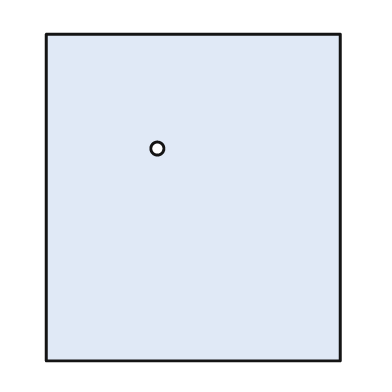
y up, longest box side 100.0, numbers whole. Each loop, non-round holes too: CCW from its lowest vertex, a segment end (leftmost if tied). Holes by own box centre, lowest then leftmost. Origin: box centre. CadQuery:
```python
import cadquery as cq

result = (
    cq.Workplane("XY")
    .moveTo(-45.0, -50.0)
    .lineTo(45.0, -50.0)
    .lineTo(45.0, 50.0)
    .lineTo(-45.0, 50.0)
    .close()
    .moveTo(-11.0, 15.0)
    .circle(2.0)
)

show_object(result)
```